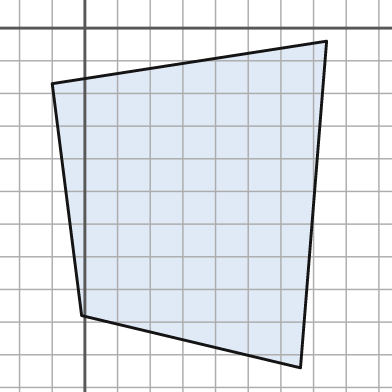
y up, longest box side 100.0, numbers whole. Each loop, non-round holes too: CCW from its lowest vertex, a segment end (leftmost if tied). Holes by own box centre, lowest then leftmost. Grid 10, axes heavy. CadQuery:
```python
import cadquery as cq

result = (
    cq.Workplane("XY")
    .moveTo(66.0, -104.0)
    .lineTo(74.0, -4.0)
    .lineTo(-10.0, -17.0)
    .lineTo(-1.0, -88.0)
    .close()
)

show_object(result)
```